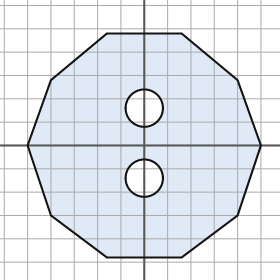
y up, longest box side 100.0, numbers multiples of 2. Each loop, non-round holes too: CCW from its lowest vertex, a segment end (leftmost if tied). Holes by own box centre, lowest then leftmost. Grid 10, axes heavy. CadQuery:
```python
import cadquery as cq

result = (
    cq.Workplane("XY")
    .moveTo(-16.0, -48.0)
    .lineTo(16.0, -48.0)
    .lineTo(40.0, -30.0)
    .lineTo(50.0, 0.0)
    .lineTo(40.0, 28.0)
    .lineTo(16.0, 48.0)
    .lineTo(-16.0, 48.0)
    .lineTo(-40.0, 28.0)
    .lineTo(-50.0, 0.0)
    .lineTo(-40.0, -30.0)
    .close()
    .moveTo(0.0, -14.0)
    .circle(8.0)
    .moveTo(0.0, 16.0)
    .circle(8.0)
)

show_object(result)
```